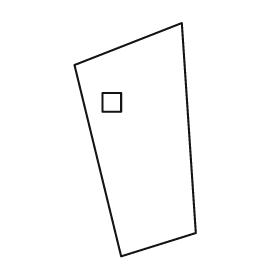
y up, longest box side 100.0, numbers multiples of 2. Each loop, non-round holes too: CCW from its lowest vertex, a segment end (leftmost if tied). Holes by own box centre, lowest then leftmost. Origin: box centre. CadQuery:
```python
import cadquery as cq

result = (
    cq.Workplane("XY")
    .moveTo(-6.0, -50.0)
    .lineTo(26.0, -40.0)
    .lineTo(20.0, 50.0)
    .lineTo(-26.0, 32.0)
    .close()
    .moveTo(-14.0, 12.0)
    .lineTo(-6.0, 12.0)
    .lineTo(-6.0, 20.0)
    .lineTo(-14.0, 20.0)
    .close()
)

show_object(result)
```